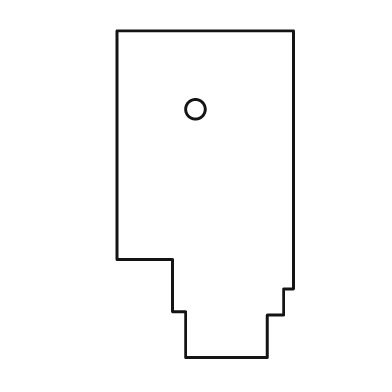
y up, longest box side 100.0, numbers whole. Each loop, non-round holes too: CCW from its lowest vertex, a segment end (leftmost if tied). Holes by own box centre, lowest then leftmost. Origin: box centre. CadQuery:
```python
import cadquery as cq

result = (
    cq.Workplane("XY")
    .moveTo(-6.0, -50.0)
    .lineTo(19.0, -50.0)
    .lineTo(19.0, -37.0)
    .lineTo(24.0, -37.0)
    .lineTo(24.0, -29.0)
    .lineTo(27.0, -29.0)
    .lineTo(27.0, 50.0)
    .lineTo(-27.0, 50.0)
    .lineTo(-27.0, -20.0)
    .lineTo(-10.0, -20.0)
    .lineTo(-10.0, -36.0)
    .lineTo(-6.0, -36.0)
    .close()
    .moveTo(-3.0, 26.0)
    .circle(3.0)
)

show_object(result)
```